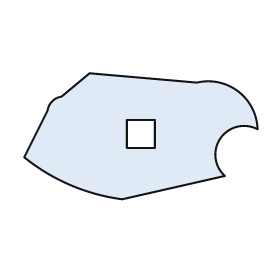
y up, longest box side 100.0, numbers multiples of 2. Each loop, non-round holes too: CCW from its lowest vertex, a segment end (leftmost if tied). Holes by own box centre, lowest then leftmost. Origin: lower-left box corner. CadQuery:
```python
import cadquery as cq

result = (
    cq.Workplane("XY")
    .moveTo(42.0, 0.0)
    .lineTo(86.0, 10.0)
    .threePointArc((84.0, 26.0), (100.0, 30.0))
    .threePointArc((92.0, 46.0), (74.0, 50.0))
    .lineTo(28.0, 54.0)
    .lineTo(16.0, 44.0)
    .threePointArc((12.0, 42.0), (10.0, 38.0))
    .lineTo(0.0, 18.0)
    .threePointArc((20.0, 6.0), (42.0, 0.0))
    .close()
    .moveTo(44.0, 22.0)
    .lineTo(56.0, 22.0)
    .lineTo(56.0, 34.0)
    .lineTo(44.0, 34.0)
    .close()
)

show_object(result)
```